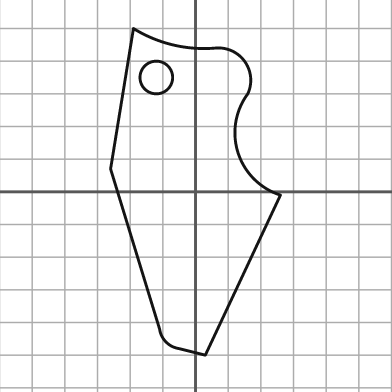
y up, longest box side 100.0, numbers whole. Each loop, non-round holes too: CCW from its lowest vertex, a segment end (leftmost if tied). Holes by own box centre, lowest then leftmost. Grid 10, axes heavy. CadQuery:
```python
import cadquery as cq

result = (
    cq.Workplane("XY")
    .moveTo(3.0, -50.0)
    .lineTo(26.0, -1.0)
    .threePointArc((13.0, 12.0), (16.0, 30.0))
    .threePointArc((15.0, 40.0), (6.0, 44.0))
    .threePointArc((-7.0, 45.0), (-19.0, 50.0))
    .lineTo(-26.0, 7.0)
    .lineTo(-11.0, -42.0)
    .threePointArc((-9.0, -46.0), (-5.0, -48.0))
    .close()
    .moveTo(-12.0, 35.0)
    .circle(5.0)
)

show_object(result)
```